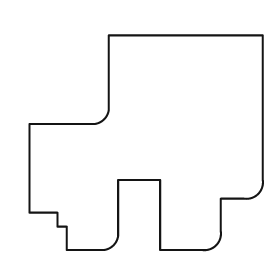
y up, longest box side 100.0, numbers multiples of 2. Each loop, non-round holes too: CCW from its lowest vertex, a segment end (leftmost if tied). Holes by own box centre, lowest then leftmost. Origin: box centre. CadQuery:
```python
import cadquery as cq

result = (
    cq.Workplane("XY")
    .moveTo(-34.0, -46.0)
    .lineTo(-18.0, -46.0)
    .threePointArc((-14.0, -44.0), (-12.0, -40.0))
    .lineTo(-12.0, -16.0)
    .lineTo(6.0, -16.0)
    .lineTo(6.0, -46.0)
    .lineTo(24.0, -46.0)
    .threePointArc((30.0, -44.0), (32.0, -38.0))
    .lineTo(32.0, -24.0)
    .lineTo(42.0, -24.0)
    .threePointArc((48.0, -22.0), (50.0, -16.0))
    .lineTo(50.0, 46.0)
    .lineTo(-16.0, 46.0)
    .lineTo(-16.0, 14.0)
    .threePointArc((-18.0, 10.0), (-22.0, 8.0))
    .lineTo(-50.0, 8.0)
    .lineTo(-50.0, -30.0)
    .lineTo(-38.0, -30.0)
    .lineTo(-38.0, -36.0)
    .lineTo(-34.0, -36.0)
    .close()
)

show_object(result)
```